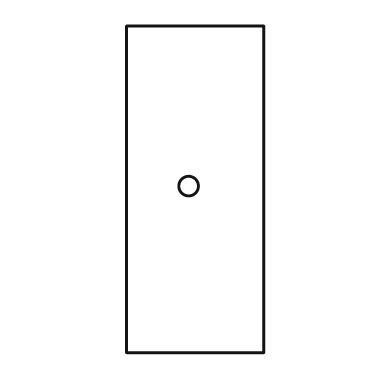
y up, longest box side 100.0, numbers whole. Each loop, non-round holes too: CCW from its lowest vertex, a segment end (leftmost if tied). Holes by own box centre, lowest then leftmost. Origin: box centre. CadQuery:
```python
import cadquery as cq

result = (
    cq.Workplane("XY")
    .moveTo(-21.0, -50.0)
    .lineTo(21.0, -50.0)
    .lineTo(21.0, 50.0)
    .lineTo(-21.0, 50.0)
    .close()
    .moveTo(-2.0, 1.0)
    .circle(3.0)
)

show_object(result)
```